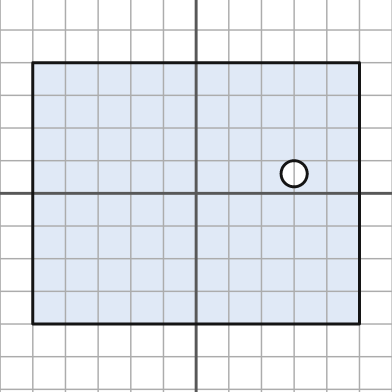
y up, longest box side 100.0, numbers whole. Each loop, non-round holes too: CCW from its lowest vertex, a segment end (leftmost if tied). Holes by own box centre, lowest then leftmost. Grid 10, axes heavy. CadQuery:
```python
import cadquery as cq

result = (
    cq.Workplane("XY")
    .moveTo(-50.0, -40.0)
    .lineTo(50.0, -40.0)
    .lineTo(50.0, 40.0)
    .lineTo(-50.0, 40.0)
    .close()
    .moveTo(30.0, 6.0)
    .circle(4.0)
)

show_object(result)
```